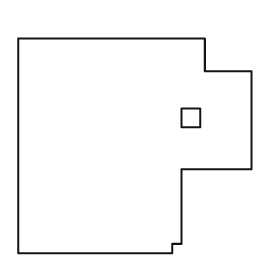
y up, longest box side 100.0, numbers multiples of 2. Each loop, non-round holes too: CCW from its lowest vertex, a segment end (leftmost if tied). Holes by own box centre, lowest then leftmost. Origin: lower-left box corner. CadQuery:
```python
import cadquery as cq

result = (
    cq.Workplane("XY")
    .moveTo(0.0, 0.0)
    .lineTo(66.0, 0.0)
    .lineTo(66.0, 4.0)
    .lineTo(70.0, 4.0)
    .lineTo(70.0, 36.0)
    .lineTo(100.0, 36.0)
    .lineTo(100.0, 78.0)
    .lineTo(80.0, 78.0)
    .lineTo(80.0, 92.0)
    .lineTo(0.0, 92.0)
    .close()
    .moveTo(70.0, 54.0)
    .lineTo(78.0, 54.0)
    .lineTo(78.0, 62.0)
    .lineTo(70.0, 62.0)
    .close()
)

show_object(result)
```